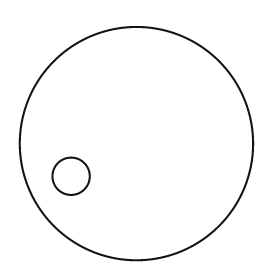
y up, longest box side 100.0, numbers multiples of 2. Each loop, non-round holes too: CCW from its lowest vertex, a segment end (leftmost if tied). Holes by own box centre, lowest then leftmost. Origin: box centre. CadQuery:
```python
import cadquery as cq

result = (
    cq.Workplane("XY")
    .moveTo(0.0, 0.0)
    .circle(50.0)
    .moveTo(-28.0, -14.0)
    .circle(8.0)
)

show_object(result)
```